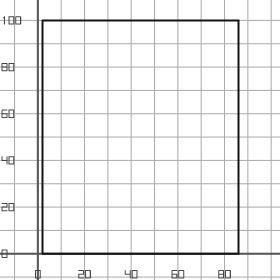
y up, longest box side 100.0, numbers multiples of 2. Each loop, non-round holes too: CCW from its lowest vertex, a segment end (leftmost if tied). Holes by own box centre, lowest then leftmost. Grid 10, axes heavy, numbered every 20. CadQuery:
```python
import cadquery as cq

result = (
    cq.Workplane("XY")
    .moveTo(2.0, 0.0)
    .lineTo(86.0, 0.0)
    .lineTo(86.0, 100.0)
    .lineTo(2.0, 100.0)
    .close()
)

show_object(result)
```